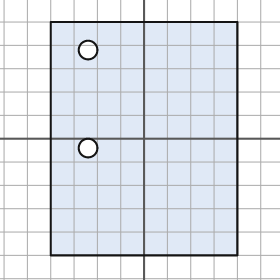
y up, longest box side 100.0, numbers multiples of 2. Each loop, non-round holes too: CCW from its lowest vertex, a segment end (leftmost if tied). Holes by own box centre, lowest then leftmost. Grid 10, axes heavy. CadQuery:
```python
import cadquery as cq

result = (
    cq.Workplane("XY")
    .moveTo(-40.0, -50.0)
    .lineTo(40.0, -50.0)
    .lineTo(40.0, 50.0)
    .lineTo(-40.0, 50.0)
    .close()
    .moveTo(-24.0, -4.0)
    .circle(4.0)
    .moveTo(-24.0, 38.0)
    .circle(4.0)
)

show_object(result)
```